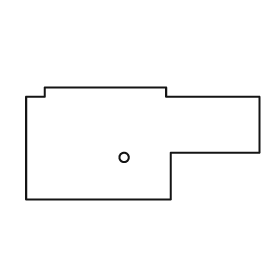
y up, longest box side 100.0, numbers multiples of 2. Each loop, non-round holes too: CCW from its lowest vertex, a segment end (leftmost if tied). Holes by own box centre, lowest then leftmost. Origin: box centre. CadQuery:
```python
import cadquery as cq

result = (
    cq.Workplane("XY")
    .moveTo(-50.0, -24.0)
    .lineTo(12.0, -24.0)
    .lineTo(12.0, -4.0)
    .lineTo(50.0, -4.0)
    .lineTo(50.0, 20.0)
    .lineTo(10.0, 20.0)
    .lineTo(10.0, 24.0)
    .lineTo(-42.0, 24.0)
    .lineTo(-42.0, 20.0)
    .lineTo(-50.0, 20.0)
    .close()
    .moveTo(-8.0, -6.0)
    .circle(2.0)
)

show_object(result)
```